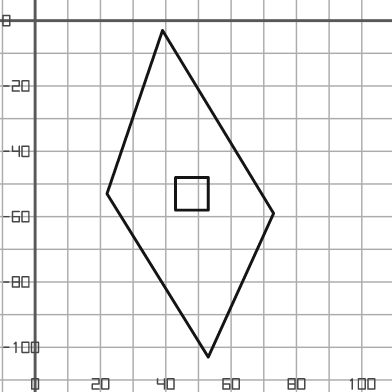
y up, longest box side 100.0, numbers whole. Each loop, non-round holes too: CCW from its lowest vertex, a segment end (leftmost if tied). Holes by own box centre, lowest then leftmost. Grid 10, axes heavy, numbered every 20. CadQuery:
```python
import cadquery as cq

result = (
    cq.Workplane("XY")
    .moveTo(53.0, -103.0)
    .lineTo(73.0, -59.0)
    .lineTo(39.0, -3.0)
    .lineTo(22.0, -53.0)
    .close()
    .moveTo(43.0, -58.0)
    .lineTo(53.0, -58.0)
    .lineTo(53.0, -48.0)
    .lineTo(43.0, -48.0)
    .close()
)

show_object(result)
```